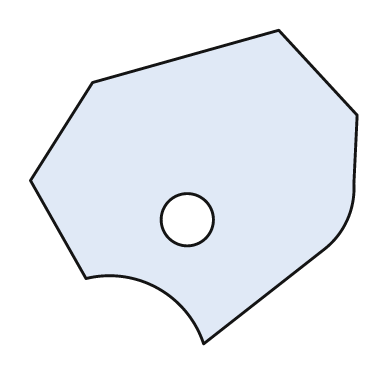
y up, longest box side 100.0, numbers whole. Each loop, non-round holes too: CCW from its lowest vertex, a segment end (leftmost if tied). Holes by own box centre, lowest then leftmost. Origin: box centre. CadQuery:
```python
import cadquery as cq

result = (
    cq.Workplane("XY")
    .moveTo(3.0, -48.0)
    .lineTo(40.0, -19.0)
    .threePointArc((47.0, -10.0), (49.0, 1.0))
    .lineTo(50.0, 22.0)
    .lineTo(26.0, 48.0)
    .lineTo(-31.0, 32.0)
    .lineTo(-50.0, 2.0)
    .lineTo(-33.0, -28.0)
    .threePointArc((-11.0, -31.0), (3.0, -48.0))
    .close()
    .moveTo(-2.0, -10.0)
    .circle(8.0)
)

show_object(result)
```